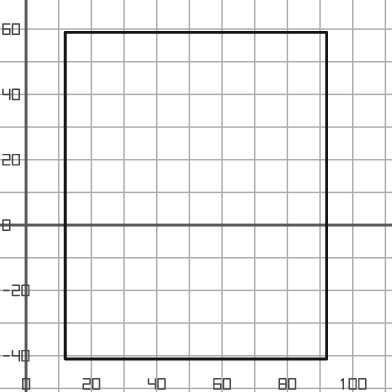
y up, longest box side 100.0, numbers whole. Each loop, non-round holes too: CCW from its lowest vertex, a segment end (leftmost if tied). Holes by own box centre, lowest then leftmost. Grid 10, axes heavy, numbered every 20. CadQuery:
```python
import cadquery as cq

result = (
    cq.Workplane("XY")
    .moveTo(12.0, -41.0)
    .lineTo(92.0, -41.0)
    .lineTo(92.0, 59.0)
    .lineTo(12.0, 59.0)
    .close()
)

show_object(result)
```